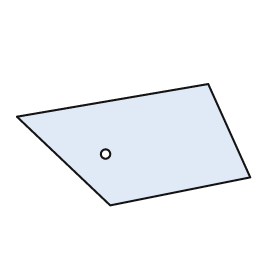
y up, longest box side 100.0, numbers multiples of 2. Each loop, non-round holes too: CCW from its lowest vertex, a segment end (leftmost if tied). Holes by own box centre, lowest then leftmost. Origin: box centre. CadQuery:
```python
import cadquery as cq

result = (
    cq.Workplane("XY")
    .moveTo(-10.0, -26.0)
    .lineTo(50.0, -14.0)
    .lineTo(32.0, 26.0)
    .lineTo(-50.0, 12.0)
    .close()
    .moveTo(-12.0, -4.0)
    .circle(2.0)
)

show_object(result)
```